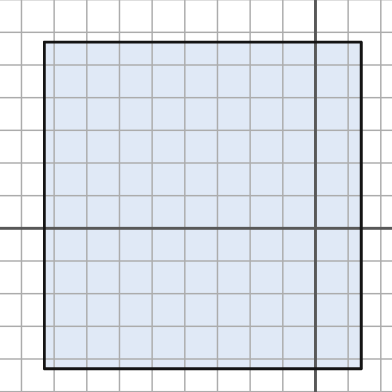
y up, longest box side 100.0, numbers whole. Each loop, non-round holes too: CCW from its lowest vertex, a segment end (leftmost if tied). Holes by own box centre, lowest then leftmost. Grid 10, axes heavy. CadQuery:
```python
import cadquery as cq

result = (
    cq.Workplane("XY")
    .moveTo(-83.0, -43.0)
    .lineTo(14.0, -43.0)
    .lineTo(14.0, 57.0)
    .lineTo(-83.0, 57.0)
    .close()
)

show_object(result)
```